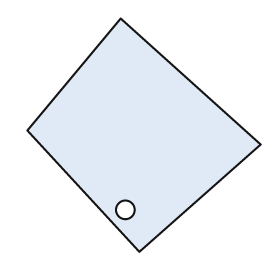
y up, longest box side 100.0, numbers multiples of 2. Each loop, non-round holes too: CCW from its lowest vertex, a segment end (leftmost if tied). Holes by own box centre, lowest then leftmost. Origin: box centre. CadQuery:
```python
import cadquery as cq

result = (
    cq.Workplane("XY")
    .moveTo(-2.0, -50.0)
    .lineTo(50.0, -4.0)
    .lineTo(-10.0, 50.0)
    .lineTo(-50.0, 2.0)
    .close()
    .moveTo(-8.0, -32.0)
    .circle(4.0)
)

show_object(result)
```